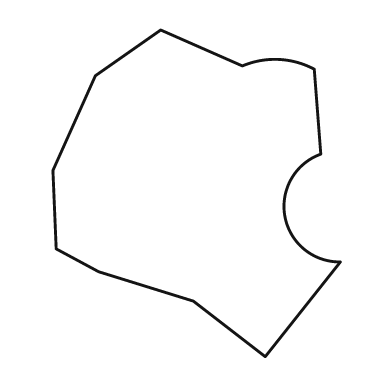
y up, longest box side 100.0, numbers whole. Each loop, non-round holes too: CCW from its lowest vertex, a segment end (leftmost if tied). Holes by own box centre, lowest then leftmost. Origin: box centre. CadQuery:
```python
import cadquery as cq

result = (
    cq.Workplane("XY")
    .moveTo(21.0, -50.0)
    .lineTo(44.0, -21.0)
    .threePointArc((27.0, -7.0), (38.0, 12.0))
    .lineTo(36.0, 38.0)
    .threePointArc((25.0, 41.0), (14.0, 39.0))
    .lineTo(-11.0, 50.0)
    .lineTo(-31.0, 36.0)
    .lineTo(-44.0, 7.0)
    .lineTo(-43.0, -17.0)
    .lineTo(-30.0, -24.0)
    .lineTo(-1.0, -33.0)
    .close()
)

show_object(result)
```